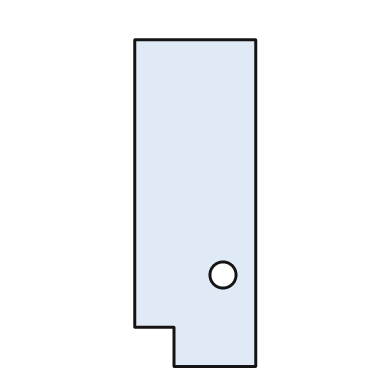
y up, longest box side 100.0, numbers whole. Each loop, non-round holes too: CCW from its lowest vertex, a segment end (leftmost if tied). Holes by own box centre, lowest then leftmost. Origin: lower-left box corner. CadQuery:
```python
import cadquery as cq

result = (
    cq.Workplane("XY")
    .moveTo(12.0, 0.0)
    .lineTo(37.0, 0.0)
    .lineTo(37.0, 100.0)
    .lineTo(0.0, 100.0)
    .lineTo(0.0, 12.0)
    .lineTo(12.0, 12.0)
    .close()
    .moveTo(27.0, 28.0)
    .circle(4.0)
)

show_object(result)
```